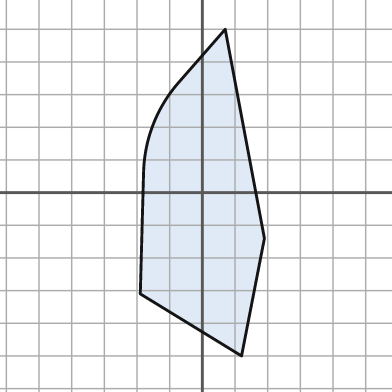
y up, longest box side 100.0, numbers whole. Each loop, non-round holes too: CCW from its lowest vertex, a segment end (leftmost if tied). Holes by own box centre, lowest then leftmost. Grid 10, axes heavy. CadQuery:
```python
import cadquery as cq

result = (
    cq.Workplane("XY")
    .moveTo(12.0, -50.0)
    .lineTo(19.0, -14.0)
    .lineTo(7.0, 50.0)
    .lineTo(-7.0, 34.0)
    .threePointArc((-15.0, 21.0), (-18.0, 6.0))
    .lineTo(-19.0, -31.0)
    .close()
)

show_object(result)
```